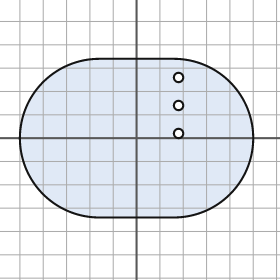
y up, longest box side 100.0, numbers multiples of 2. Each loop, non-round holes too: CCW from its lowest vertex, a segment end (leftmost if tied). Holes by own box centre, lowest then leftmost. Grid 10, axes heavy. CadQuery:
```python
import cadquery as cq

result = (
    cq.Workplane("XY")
    .moveTo(-16.0, -34.0)
    .lineTo(16.0, -34.0)
    .threePointArc((50.0, 0.0), (16.0, 34.0))
    .lineTo(-16.0, 34.0)
    .threePointArc((-50.0, 0.0), (-16.0, -34.0))
    .close()
    .moveTo(18.0, 2.0)
    .circle(2.0)
    .moveTo(18.0, 14.0)
    .circle(2.0)
    .moveTo(18.0, 26.0)
    .circle(2.0)
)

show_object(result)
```